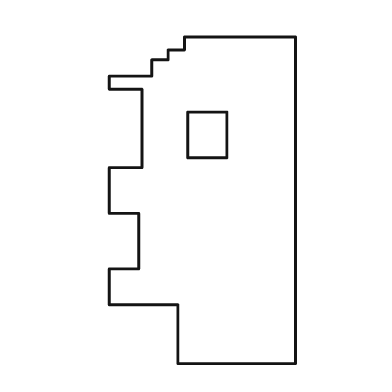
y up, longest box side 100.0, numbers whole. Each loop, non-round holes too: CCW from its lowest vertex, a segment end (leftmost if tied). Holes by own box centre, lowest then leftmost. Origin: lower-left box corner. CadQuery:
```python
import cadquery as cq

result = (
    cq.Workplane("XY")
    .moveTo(21.0, 0.0)
    .lineTo(57.0, 0.0)
    .lineTo(57.0, 100.0)
    .lineTo(23.0, 100.0)
    .lineTo(23.0, 96.0)
    .lineTo(18.0, 96.0)
    .lineTo(18.0, 93.0)
    .lineTo(13.0, 93.0)
    .lineTo(13.0, 88.0)
    .lineTo(0.0, 88.0)
    .lineTo(0.0, 84.0)
    .lineTo(10.0, 84.0)
    .lineTo(10.0, 60.0)
    .lineTo(0.0, 60.0)
    .lineTo(0.0, 46.0)
    .lineTo(9.0, 46.0)
    .lineTo(9.0, 29.0)
    .lineTo(0.0, 29.0)
    .lineTo(0.0, 18.0)
    .lineTo(21.0, 18.0)
    .close()
    .moveTo(24.0, 63.0)
    .lineTo(36.0, 63.0)
    .lineTo(36.0, 77.0)
    .lineTo(24.0, 77.0)
    .close()
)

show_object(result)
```